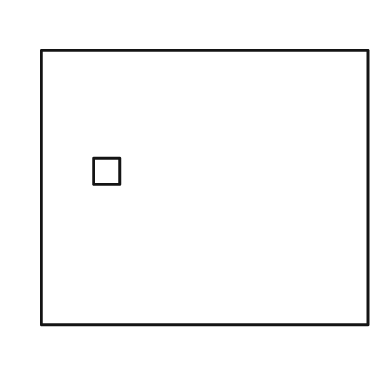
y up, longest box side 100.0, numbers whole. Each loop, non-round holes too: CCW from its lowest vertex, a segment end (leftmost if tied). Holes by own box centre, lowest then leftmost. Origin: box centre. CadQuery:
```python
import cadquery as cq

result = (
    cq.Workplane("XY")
    .moveTo(-50.0, -42.0)
    .lineTo(50.0, -42.0)
    .lineTo(50.0, 42.0)
    .lineTo(-50.0, 42.0)
    .close()
    .moveTo(-34.0, 1.0)
    .lineTo(-26.0, 1.0)
    .lineTo(-26.0, 9.0)
    .lineTo(-34.0, 9.0)
    .close()
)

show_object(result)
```